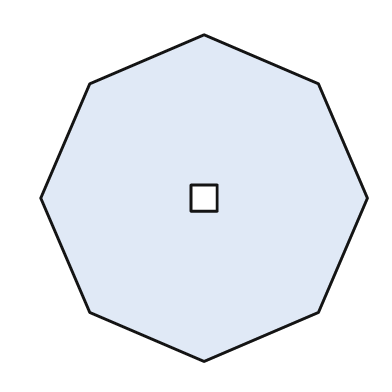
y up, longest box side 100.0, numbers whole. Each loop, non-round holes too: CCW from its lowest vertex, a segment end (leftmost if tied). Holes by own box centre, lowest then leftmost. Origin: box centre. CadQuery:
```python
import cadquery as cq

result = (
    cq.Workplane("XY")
    .moveTo(0.0, -50.0)
    .lineTo(35.0, -35.0)
    .lineTo(50.0, 0.0)
    .lineTo(35.0, 35.0)
    .lineTo(0.0, 50.0)
    .lineTo(-35.0, 35.0)
    .lineTo(-50.0, 0.0)
    .lineTo(-35.0, -35.0)
    .close()
    .moveTo(-4.0, -4.0)
    .lineTo(4.0, -4.0)
    .lineTo(4.0, 4.0)
    .lineTo(-4.0, 4.0)
    .close()
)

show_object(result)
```